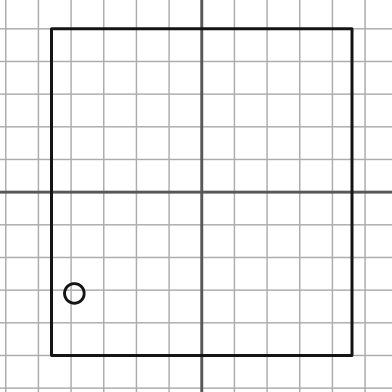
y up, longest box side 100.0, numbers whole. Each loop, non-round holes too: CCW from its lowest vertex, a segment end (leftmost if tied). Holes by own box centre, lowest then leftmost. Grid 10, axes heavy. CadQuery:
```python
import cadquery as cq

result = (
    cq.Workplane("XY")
    .moveTo(-46.0, -50.0)
    .lineTo(46.0, -50.0)
    .lineTo(46.0, 50.0)
    .lineTo(-46.0, 50.0)
    .close()
    .moveTo(-39.0, -31.0)
    .circle(3.0)
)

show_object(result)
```